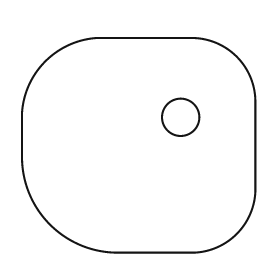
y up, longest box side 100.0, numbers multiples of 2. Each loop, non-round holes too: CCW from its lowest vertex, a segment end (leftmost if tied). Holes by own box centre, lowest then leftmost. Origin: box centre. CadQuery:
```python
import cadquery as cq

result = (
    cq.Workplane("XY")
    .moveTo(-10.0, -46.0)
    .lineTo(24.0, -46.0)
    .threePointArc((42.0, -38.0), (50.0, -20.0))
    .lineTo(50.0, 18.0)
    .threePointArc((42.0, 38.0), (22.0, 46.0))
    .lineTo(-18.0, 46.0)
    .threePointArc((-40.0, 36.0), (-50.0, 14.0))
    .lineTo(-50.0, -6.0)
    .threePointArc((-38.0, -34.0), (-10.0, -46.0))
    .close()
    .moveTo(18.0, 12.0)
    .circle(8.0)
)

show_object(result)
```